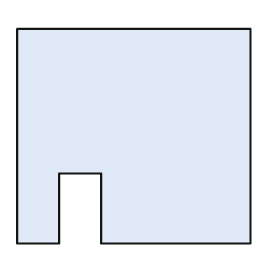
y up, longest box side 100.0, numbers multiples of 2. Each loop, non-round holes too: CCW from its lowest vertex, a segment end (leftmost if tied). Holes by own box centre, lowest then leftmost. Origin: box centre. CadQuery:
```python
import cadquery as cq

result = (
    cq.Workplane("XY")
    .moveTo(-50.0, -46.0)
    .lineTo(-32.0, -46.0)
    .lineTo(-32.0, -16.0)
    .lineTo(-14.0, -16.0)
    .lineTo(-14.0, -46.0)
    .lineTo(50.0, -46.0)
    .lineTo(50.0, 46.0)
    .lineTo(-50.0, 46.0)
    .close()
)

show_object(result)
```